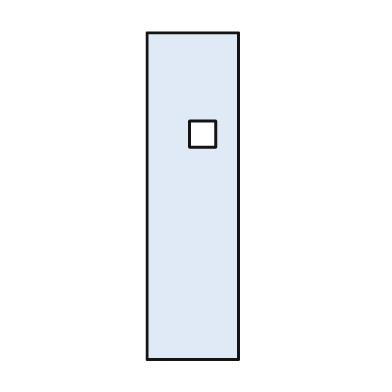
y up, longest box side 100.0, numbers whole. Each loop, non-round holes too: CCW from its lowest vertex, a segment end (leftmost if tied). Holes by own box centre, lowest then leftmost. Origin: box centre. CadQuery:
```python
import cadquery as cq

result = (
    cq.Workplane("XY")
    .moveTo(-14.0, -50.0)
    .lineTo(14.0, -50.0)
    .lineTo(14.0, 50.0)
    .lineTo(-14.0, 50.0)
    .close()
    .moveTo(-1.0, 15.0)
    .lineTo(7.0, 15.0)
    .lineTo(7.0, 23.0)
    .lineTo(-1.0, 23.0)
    .close()
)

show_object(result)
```